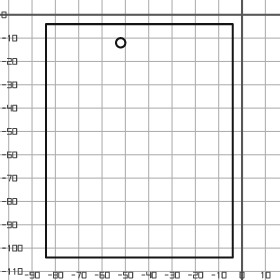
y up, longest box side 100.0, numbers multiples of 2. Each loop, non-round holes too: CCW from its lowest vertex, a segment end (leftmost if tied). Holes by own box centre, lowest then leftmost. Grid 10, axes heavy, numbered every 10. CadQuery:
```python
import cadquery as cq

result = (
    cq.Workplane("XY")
    .moveTo(-84.0, -104.0)
    .lineTo(-4.0, -104.0)
    .lineTo(-4.0, -4.0)
    .lineTo(-84.0, -4.0)
    .close()
    .moveTo(-52.0, -12.0)
    .circle(2.0)
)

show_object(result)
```